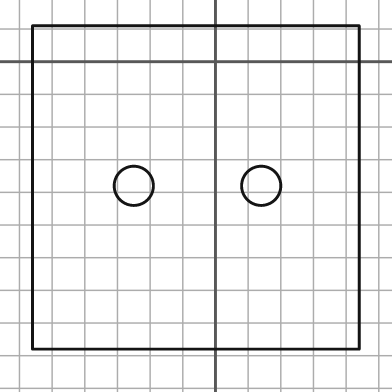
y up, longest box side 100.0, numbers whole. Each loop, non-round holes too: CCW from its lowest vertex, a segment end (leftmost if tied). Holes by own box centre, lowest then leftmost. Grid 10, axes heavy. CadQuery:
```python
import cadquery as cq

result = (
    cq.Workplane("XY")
    .moveTo(-56.0, -88.0)
    .lineTo(44.0, -88.0)
    .lineTo(44.0, 11.0)
    .lineTo(-56.0, 11.0)
    .close()
    .moveTo(-25.0, -38.0)
    .circle(6.0)
    .moveTo(14.0, -38.0)
    .circle(6.0)
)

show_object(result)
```